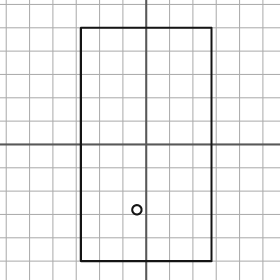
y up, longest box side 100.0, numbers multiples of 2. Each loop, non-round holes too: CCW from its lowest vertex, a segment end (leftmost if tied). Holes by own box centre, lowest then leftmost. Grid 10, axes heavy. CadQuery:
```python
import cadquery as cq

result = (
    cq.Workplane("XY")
    .moveTo(-28.0, -50.0)
    .lineTo(28.0, -50.0)
    .lineTo(28.0, 50.0)
    .lineTo(-28.0, 50.0)
    .close()
    .moveTo(-4.0, -28.0)
    .circle(2.0)
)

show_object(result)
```